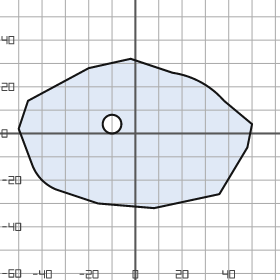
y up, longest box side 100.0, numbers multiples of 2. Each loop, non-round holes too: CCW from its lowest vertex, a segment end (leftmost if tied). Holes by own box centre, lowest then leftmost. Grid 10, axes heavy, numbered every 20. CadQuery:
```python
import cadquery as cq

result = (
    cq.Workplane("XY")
    .moveTo(8.0, -32.0)
    .lineTo(36.0, -26.0)
    .lineTo(48.0, -6.0)
    .lineTo(50.0, 4.0)
    .lineTo(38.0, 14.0)
    .threePointArc((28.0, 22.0), (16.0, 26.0))
    .lineTo(-2.0, 32.0)
    .lineTo(-20.0, 28.0)
    .lineTo(-46.0, 14.0)
    .lineTo(-50.0, 2.0)
    .lineTo(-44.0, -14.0)
    .threePointArc((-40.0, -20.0), (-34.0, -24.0))
    .lineTo(-16.0, -30.0)
    .close()
    .moveTo(-10.0, 4.0)
    .circle(4.0)
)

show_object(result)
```